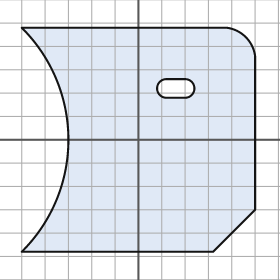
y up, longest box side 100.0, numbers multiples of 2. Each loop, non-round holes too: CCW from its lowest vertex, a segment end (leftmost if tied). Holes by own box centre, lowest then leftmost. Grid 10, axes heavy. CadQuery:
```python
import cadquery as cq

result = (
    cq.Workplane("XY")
    .moveTo(-50.0, -48.0)
    .lineTo(32.0, -48.0)
    .lineTo(50.0, -30.0)
    .lineTo(50.0, 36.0)
    .threePointArc((46.0, 44.0), (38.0, 48.0))
    .lineTo(-50.0, 48.0)
    .threePointArc((-30.0, 0.0), (-50.0, -48.0))
    .close()
    .moveTo(12.0, 18.0)
    .lineTo(20.0, 18.0)
    .threePointArc((24.0, 22.0), (20.0, 26.0))
    .lineTo(12.0, 26.0)
    .threePointArc((8.0, 22.0), (12.0, 18.0))
    .close()
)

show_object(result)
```